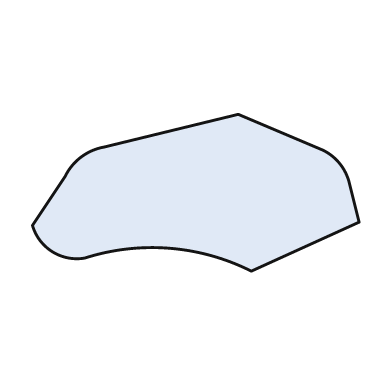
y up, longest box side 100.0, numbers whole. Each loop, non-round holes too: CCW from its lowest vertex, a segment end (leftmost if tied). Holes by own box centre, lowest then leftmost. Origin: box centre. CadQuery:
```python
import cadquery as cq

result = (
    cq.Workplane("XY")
    .moveTo(17.0, -24.0)
    .lineTo(50.0, -9.0)
    .lineTo(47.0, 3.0)
    .threePointArc((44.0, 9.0), (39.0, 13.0))
    .lineTo(13.0, 24.0)
    .lineTo(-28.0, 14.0)
    .threePointArc((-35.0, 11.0), (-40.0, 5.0))
    .lineTo(-50.0, -10.0)
    .threePointArc((-44.0, -18.0), (-34.0, -20.0))
    .threePointArc((-8.0, -17.0), (17.0, -24.0))
    .close()
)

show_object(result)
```